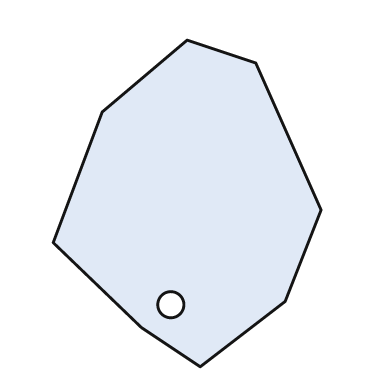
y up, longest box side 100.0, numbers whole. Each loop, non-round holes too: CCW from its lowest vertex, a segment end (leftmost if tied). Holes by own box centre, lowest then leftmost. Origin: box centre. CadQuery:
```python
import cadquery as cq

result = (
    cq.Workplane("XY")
    .moveTo(4.0, -50.0)
    .lineTo(30.0, -30.0)
    .lineTo(41.0, -2.0)
    .lineTo(21.0, 43.0)
    .lineTo(0.0, 50.0)
    .lineTo(-26.0, 28.0)
    .lineTo(-41.0, -12.0)
    .lineTo(-14.0, -38.0)
    .close()
    .moveTo(-5.0, -31.0)
    .circle(4.0)
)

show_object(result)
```